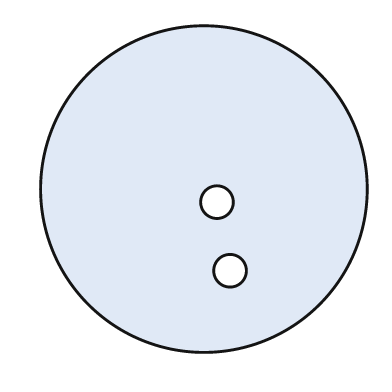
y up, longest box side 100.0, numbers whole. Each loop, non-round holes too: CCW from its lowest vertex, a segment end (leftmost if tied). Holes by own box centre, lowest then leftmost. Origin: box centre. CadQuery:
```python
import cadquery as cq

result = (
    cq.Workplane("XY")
    .moveTo(0.0, 0.0)
    .circle(50.0)
    .moveTo(8.0, -25.0)
    .circle(5.0)
    .moveTo(4.0, -4.0)
    .circle(5.0)
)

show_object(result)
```